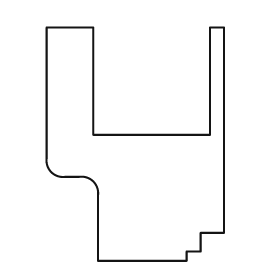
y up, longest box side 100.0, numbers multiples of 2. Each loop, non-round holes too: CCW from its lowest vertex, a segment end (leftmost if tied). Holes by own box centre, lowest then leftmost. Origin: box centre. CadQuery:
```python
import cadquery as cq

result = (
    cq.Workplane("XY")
    .moveTo(-16.0, -50.0)
    .lineTo(22.0, -50.0)
    .lineTo(22.0, -46.0)
    .lineTo(28.0, -46.0)
    .lineTo(28.0, -38.0)
    .lineTo(38.0, -38.0)
    .lineTo(38.0, 50.0)
    .lineTo(32.0, 50.0)
    .lineTo(32.0, 4.0)
    .lineTo(-18.0, 4.0)
    .lineTo(-18.0, 50.0)
    .lineTo(-38.0, 50.0)
    .lineTo(-38.0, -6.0)
    .threePointArc((-36.0, -12.0), (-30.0, -14.0))
    .lineTo(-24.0, -14.0)
    .threePointArc((-18.0, -16.0), (-16.0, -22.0))
    .close()
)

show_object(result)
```